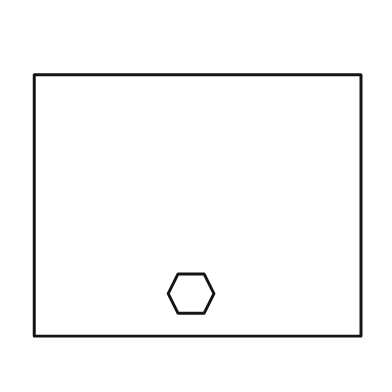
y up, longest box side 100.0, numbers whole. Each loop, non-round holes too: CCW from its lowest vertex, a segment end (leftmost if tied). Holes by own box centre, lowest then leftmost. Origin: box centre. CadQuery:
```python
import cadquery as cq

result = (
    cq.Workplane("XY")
    .moveTo(-50.0, -40.0)
    .lineTo(50.0, -40.0)
    .lineTo(50.0, 40.0)
    .lineTo(-50.0, 40.0)
    .close()
    .moveTo(-6.0, -33.0)
    .lineTo(2.0, -33.0)
    .lineTo(5.0, -27.0)
    .lineTo(2.0, -21.0)
    .lineTo(-6.0, -21.0)
    .lineTo(-9.0, -27.0)
    .close()
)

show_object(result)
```